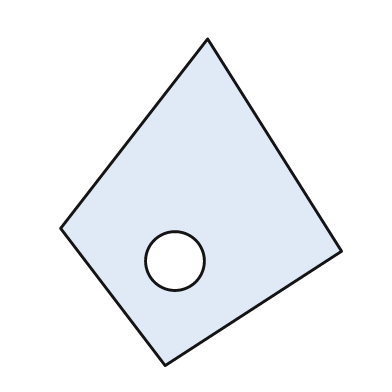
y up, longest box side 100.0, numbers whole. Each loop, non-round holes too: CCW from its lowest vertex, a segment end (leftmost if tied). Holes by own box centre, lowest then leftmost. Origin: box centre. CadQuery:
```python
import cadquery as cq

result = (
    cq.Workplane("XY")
    .moveTo(-11.0, -50.0)
    .lineTo(43.0, -15.0)
    .lineTo(2.0, 50.0)
    .lineTo(-43.0, -8.0)
    .close()
    .moveTo(-8.0, -18.0)
    .circle(9.0)
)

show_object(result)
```